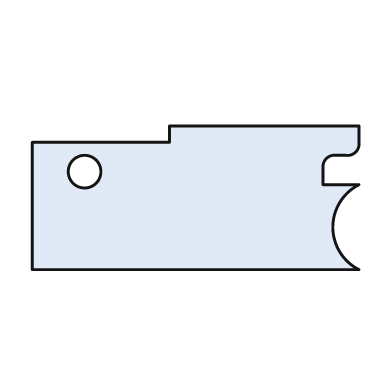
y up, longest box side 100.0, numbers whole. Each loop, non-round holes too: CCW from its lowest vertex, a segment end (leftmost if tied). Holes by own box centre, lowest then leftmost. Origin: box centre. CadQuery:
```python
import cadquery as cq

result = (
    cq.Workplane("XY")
    .moveTo(-50.0, -22.0)
    .lineTo(50.0, -22.0)
    .threePointArc((42.0, -9.0), (50.0, 4.0))
    .lineTo(39.0, 4.0)
    .lineTo(39.0, 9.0)
    .threePointArc((40.0, 12.0), (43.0, 13.0))
    .lineTo(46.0, 13.0)
    .threePointArc((49.0, 14.0), (50.0, 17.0))
    .lineTo(50.0, 22.0)
    .lineTo(-8.0, 22.0)
    .lineTo(-8.0, 17.0)
    .lineTo(-50.0, 17.0)
    .close()
    .moveTo(-34.0, 8.0)
    .circle(5.0)
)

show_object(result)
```